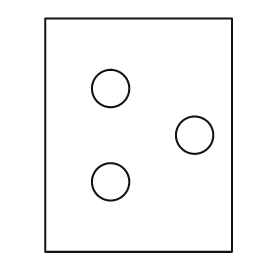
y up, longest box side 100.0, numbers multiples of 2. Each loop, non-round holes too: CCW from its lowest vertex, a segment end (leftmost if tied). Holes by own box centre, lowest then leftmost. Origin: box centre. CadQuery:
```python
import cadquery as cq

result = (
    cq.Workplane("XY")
    .moveTo(-40.0, -50.0)
    .lineTo(40.0, -50.0)
    .lineTo(40.0, 50.0)
    .lineTo(-40.0, 50.0)
    .close()
    .moveTo(-12.0, -20.0)
    .circle(8.0)
    .moveTo(24.0, 0.0)
    .circle(8.0)
    .moveTo(-12.0, 20.0)
    .circle(8.0)
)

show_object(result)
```